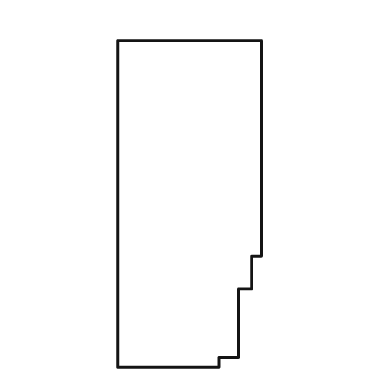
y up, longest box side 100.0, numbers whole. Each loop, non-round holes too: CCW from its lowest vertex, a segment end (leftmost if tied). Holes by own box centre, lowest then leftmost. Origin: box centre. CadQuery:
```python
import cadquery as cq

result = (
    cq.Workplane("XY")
    .moveTo(-22.0, -50.0)
    .lineTo(9.0, -50.0)
    .lineTo(9.0, -47.0)
    .lineTo(15.0, -47.0)
    .lineTo(15.0, -26.0)
    .lineTo(19.0, -26.0)
    .lineTo(19.0, -16.0)
    .lineTo(22.0, -16.0)
    .lineTo(22.0, 50.0)
    .lineTo(-22.0, 50.0)
    .close()
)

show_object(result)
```